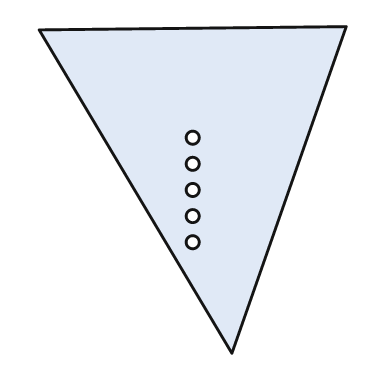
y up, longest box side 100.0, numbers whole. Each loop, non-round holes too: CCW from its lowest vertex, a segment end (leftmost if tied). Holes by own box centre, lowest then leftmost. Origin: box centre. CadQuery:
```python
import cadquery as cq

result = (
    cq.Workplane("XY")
    .moveTo(12.0, -50.0)
    .lineTo(47.0, 50.0)
    .lineTo(-47.0, 49.0)
    .close()
    .moveTo(0.0, -16.0)
    .circle(2.0)
    .moveTo(0.0, -8.0)
    .circle(2.0)
    .moveTo(0.0, 0.0)
    .circle(2.0)
    .moveTo(0.0, 8.0)
    .circle(2.0)
    .moveTo(0.0, 16.0)
    .circle(2.0)
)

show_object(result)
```